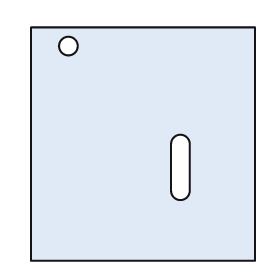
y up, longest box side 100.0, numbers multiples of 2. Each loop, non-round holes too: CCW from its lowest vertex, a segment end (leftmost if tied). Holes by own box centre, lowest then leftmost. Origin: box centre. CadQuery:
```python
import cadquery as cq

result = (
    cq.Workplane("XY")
    .moveTo(-48.0, -50.0)
    .lineTo(48.0, -50.0)
    .lineTo(48.0, 50.0)
    .lineTo(-48.0, 50.0)
    .close()
    .moveTo(12.0, -20.0)
    .threePointArc((16.0, -24.0), (20.0, -20.0))
    .lineTo(20.0, 0.0)
    .threePointArc((16.0, 4.0), (12.0, 0.0))
    .close()
    .moveTo(-32.0, 42.0)
    .circle(4.0)
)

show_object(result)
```